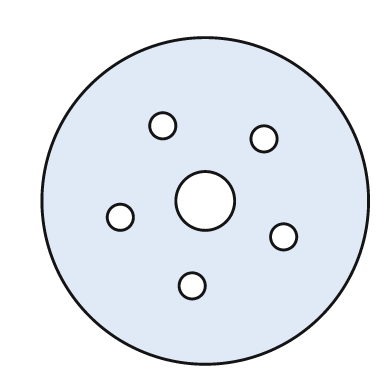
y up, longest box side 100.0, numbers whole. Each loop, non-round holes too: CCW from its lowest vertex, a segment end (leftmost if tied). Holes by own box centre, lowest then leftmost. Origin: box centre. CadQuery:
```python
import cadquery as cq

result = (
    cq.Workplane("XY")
    .moveTo(0.0, 0.0)
    .circle(50.0)
    .moveTo(-4.0, -26.0)
    .circle(4.0)
    .moveTo(24.0, -11.0)
    .circle(4.0)
    .moveTo(-26.0, -5.0)
    .circle(4.0)
    .moveTo(0.0, 0.0)
    .circle(9.0)
    .moveTo(18.0, 19.0)
    .circle(4.0)
    .moveTo(-13.0, 23.0)
    .circle(4.0)
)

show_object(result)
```